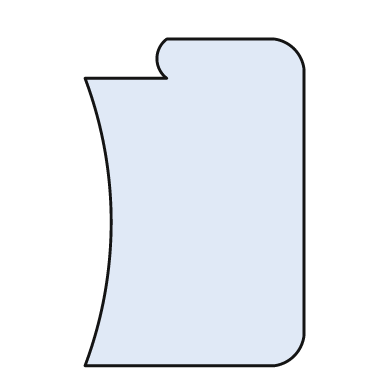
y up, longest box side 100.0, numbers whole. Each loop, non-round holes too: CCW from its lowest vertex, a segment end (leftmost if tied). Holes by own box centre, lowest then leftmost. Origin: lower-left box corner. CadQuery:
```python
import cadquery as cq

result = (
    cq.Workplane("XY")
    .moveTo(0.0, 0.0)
    .lineTo(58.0, 0.0)
    .threePointArc((64.0, 3.0), (67.0, 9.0))
    .lineTo(67.0, 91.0)
    .threePointArc((64.0, 97.0), (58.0, 100.0))
    .lineTo(25.0, 100.0)
    .threePointArc((22.0, 94.0), (25.0, 88.0))
    .lineTo(0.0, 88.0)
    .threePointArc((8.0, 44.0), (0.0, 0.0))
    .close()
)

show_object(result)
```